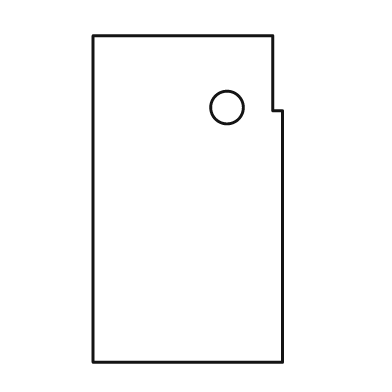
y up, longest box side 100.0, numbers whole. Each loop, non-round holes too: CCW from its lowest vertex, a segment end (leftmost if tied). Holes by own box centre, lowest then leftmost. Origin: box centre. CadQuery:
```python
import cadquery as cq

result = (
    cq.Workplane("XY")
    .moveTo(-29.0, -50.0)
    .lineTo(29.0, -50.0)
    .lineTo(29.0, 27.0)
    .lineTo(26.0, 27.0)
    .lineTo(26.0, 50.0)
    .lineTo(-29.0, 50.0)
    .close()
    .moveTo(12.0, 28.0)
    .circle(5.0)
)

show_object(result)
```